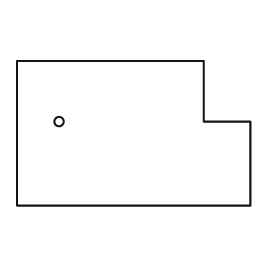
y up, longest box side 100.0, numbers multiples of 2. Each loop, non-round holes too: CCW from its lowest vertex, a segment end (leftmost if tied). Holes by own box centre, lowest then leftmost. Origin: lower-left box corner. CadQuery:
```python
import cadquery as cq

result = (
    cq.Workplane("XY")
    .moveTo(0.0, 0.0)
    .lineTo(100.0, 0.0)
    .lineTo(100.0, 36.0)
    .lineTo(80.0, 36.0)
    .lineTo(80.0, 62.0)
    .lineTo(0.0, 62.0)
    .close()
    .moveTo(18.0, 36.0)
    .circle(2.0)
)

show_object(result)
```